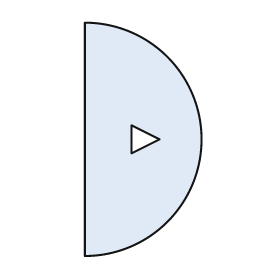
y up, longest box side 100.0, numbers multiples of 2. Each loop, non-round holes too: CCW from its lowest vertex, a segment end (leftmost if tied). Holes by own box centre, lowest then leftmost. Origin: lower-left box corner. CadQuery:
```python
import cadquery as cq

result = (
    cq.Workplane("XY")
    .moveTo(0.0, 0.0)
    .threePointArc((50.0, 50.0), (0.0, 100.0))
    .close()
    .moveTo(20.0, 44.0)
    .lineTo(32.0, 50.0)
    .lineTo(20.0, 56.0)
    .close()
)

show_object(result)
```